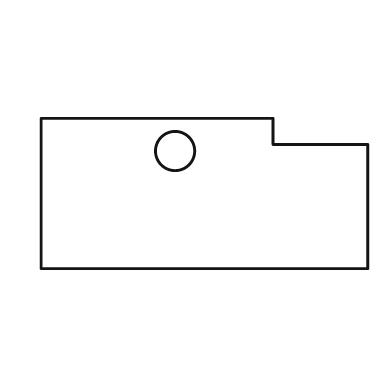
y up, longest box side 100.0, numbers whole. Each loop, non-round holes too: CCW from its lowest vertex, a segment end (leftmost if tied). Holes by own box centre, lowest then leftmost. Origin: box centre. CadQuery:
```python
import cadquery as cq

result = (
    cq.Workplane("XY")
    .moveTo(-50.0, -23.0)
    .lineTo(50.0, -23.0)
    .lineTo(50.0, 15.0)
    .lineTo(21.0, 15.0)
    .lineTo(21.0, 23.0)
    .lineTo(-50.0, 23.0)
    .close()
    .moveTo(-9.0, 13.0)
    .circle(6.0)
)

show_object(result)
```